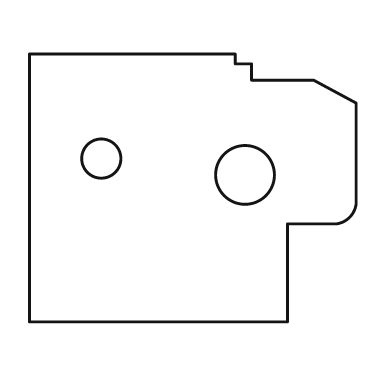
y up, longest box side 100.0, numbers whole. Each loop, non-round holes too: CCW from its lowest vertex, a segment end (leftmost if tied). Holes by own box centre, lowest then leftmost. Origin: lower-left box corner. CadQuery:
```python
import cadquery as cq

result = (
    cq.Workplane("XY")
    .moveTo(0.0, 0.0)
    .lineTo(79.0, 0.0)
    .lineTo(79.0, 30.0)
    .lineTo(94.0, 30.0)
    .threePointArc((98.0, 32.0), (100.0, 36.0))
    .lineTo(100.0, 67.0)
    .lineTo(87.0, 74.0)
    .lineTo(68.0, 74.0)
    .lineTo(68.0, 79.0)
    .lineTo(63.0, 79.0)
    .lineTo(63.0, 82.0)
    .lineTo(0.0, 82.0)
    .close()
    .moveTo(66.0, 45.0)
    .circle(9.0)
    .moveTo(22.0, 50.0)
    .circle(6.0)
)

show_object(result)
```